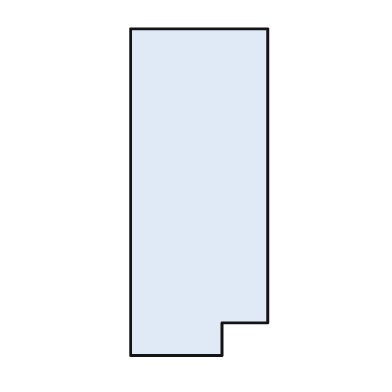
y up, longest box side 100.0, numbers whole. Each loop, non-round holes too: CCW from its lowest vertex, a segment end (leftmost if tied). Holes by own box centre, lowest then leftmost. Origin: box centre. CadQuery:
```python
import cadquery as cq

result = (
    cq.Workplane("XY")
    .moveTo(-21.0, -50.0)
    .lineTo(7.0, -50.0)
    .lineTo(7.0, -40.0)
    .lineTo(21.0, -40.0)
    .lineTo(21.0, 50.0)
    .lineTo(-21.0, 50.0)
    .close()
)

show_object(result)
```